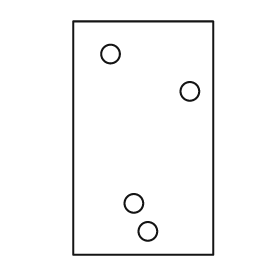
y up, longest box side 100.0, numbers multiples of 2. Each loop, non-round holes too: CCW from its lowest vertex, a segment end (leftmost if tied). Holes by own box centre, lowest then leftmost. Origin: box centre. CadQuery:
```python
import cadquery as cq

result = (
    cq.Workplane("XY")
    .moveTo(-30.0, -50.0)
    .lineTo(30.0, -50.0)
    .lineTo(30.0, 50.0)
    .lineTo(-30.0, 50.0)
    .close()
    .moveTo(2.0, -40.0)
    .circle(4.0)
    .moveTo(-4.0, -28.0)
    .circle(4.0)
    .moveTo(20.0, 20.0)
    .circle(4.0)
    .moveTo(-14.0, 36.0)
    .circle(4.0)
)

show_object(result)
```